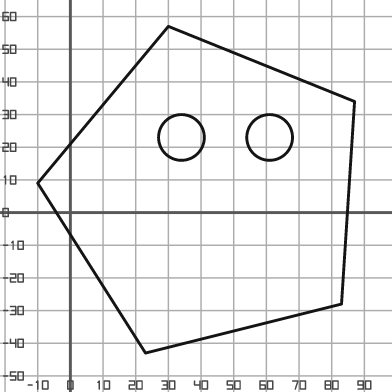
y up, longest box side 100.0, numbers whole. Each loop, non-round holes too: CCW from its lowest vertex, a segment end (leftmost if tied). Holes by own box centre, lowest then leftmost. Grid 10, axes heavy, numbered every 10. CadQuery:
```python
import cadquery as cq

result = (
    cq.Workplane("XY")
    .moveTo(23.0, -43.0)
    .lineTo(83.0, -28.0)
    .lineTo(87.0, 34.0)
    .lineTo(30.0, 57.0)
    .lineTo(-10.0, 9.0)
    .close()
    .moveTo(34.0, 23.0)
    .circle(7.0)
    .moveTo(61.0, 23.0)
    .circle(7.0)
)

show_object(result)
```